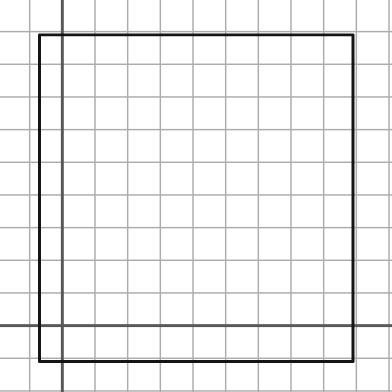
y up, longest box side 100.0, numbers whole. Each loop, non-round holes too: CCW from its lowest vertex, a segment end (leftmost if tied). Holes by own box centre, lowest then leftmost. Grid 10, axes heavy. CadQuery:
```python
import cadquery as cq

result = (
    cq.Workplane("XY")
    .moveTo(-7.0, -11.0)
    .lineTo(89.0, -11.0)
    .lineTo(89.0, 89.0)
    .lineTo(-7.0, 89.0)
    .close()
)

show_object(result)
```